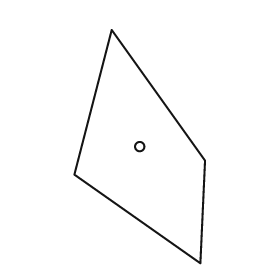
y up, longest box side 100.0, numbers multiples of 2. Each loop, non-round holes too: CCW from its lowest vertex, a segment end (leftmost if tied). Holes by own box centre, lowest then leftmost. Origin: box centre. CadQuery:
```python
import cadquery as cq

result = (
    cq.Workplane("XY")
    .moveTo(26.0, -50.0)
    .lineTo(28.0, -6.0)
    .lineTo(-12.0, 50.0)
    .lineTo(-28.0, -12.0)
    .close()
    .moveTo(0.0, 0.0)
    .circle(2.0)
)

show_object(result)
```